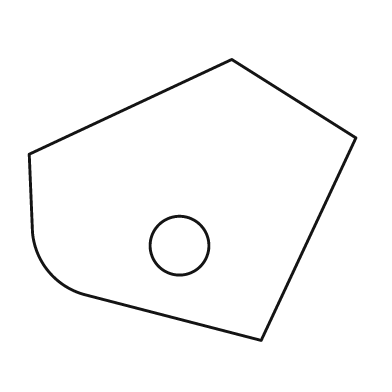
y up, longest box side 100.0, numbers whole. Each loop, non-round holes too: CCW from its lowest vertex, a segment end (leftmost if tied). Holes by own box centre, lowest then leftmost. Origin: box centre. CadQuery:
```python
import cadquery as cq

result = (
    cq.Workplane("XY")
    .moveTo(21.0, -43.0)
    .lineTo(50.0, 19.0)
    .lineTo(12.0, 43.0)
    .lineTo(-50.0, 14.0)
    .lineTo(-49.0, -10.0)
    .threePointArc((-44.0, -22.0), (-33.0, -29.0))
    .close()
    .moveTo(-4.0, -14.0)
    .circle(9.0)
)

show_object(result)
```